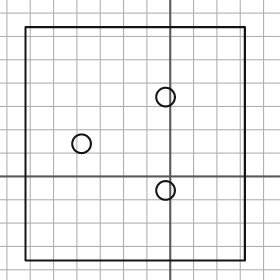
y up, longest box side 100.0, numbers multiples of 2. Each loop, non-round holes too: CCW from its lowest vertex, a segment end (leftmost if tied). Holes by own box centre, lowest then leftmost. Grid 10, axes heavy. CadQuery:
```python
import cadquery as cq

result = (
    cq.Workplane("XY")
    .moveTo(-62.0, -36.0)
    .lineTo(32.0, -36.0)
    .lineTo(32.0, 64.0)
    .lineTo(-62.0, 64.0)
    .close()
    .moveTo(-2.0, -6.0)
    .circle(4.0)
    .moveTo(-38.0, 14.0)
    .circle(4.0)
    .moveTo(-2.0, 34.0)
    .circle(4.0)
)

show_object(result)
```